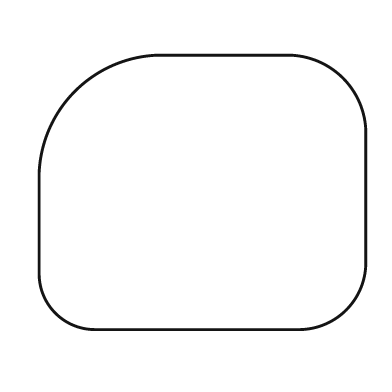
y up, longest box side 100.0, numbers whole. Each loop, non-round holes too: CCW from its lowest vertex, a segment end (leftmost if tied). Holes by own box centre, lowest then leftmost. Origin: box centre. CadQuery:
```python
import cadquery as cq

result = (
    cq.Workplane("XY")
    .moveTo(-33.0, -42.0)
    .lineTo(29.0, -42.0)
    .threePointArc((44.0, -36.0), (50.0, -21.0))
    .lineTo(50.0, 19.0)
    .threePointArc((43.0, 35.0), (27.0, 42.0))
    .lineTo(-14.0, 42.0)
    .threePointArc((-39.0, 31.0), (-50.0, 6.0))
    .lineTo(-50.0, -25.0)
    .threePointArc((-45.0, -37.0), (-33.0, -42.0))
    .close()
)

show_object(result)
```